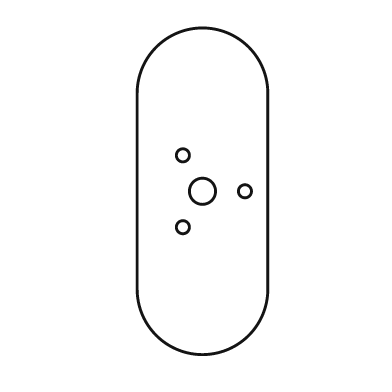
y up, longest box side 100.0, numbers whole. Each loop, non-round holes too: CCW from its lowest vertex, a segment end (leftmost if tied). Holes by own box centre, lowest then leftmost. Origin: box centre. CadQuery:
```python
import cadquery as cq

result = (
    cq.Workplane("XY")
    .moveTo(-20.0, -30.0)
    .threePointArc((0.0, -50.0), (20.0, -30.0))
    .lineTo(20.0, 30.0)
    .threePointArc((0.0, 50.0), (-20.0, 30.0))
    .close()
    .moveTo(-6.0, -11.0)
    .circle(2.0)
    .moveTo(0.0, 0.0)
    .circle(4.0)
    .moveTo(13.0, 0.0)
    .circle(2.0)
    .moveTo(-6.0, 11.0)
    .circle(2.0)
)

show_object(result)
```